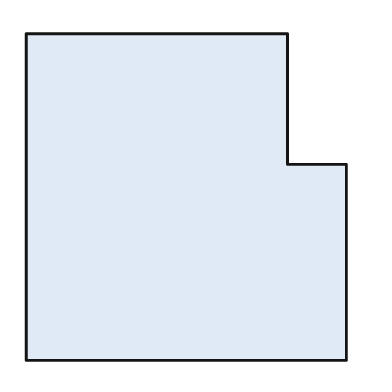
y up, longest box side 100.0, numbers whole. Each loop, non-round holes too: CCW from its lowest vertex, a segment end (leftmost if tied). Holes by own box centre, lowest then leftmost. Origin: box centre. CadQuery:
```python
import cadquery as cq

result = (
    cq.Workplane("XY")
    .moveTo(-49.0, -50.0)
    .lineTo(49.0, -50.0)
    .lineTo(49.0, 10.0)
    .lineTo(31.0, 10.0)
    .lineTo(31.0, 50.0)
    .lineTo(-49.0, 50.0)
    .close()
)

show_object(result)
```